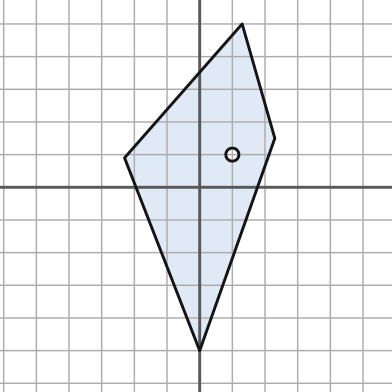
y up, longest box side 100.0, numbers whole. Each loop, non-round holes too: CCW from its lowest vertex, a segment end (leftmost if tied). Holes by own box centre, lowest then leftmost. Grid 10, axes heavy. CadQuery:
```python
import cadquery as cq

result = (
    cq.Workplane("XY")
    .moveTo(0.0, -50.0)
    .lineTo(23.0, 15.0)
    .lineTo(13.0, 50.0)
    .lineTo(-23.0, 9.0)
    .close()
    .moveTo(10.0, 10.0)
    .circle(2.0)
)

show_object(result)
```